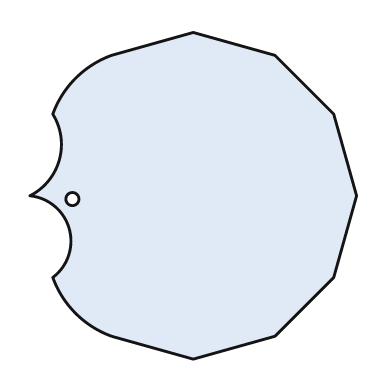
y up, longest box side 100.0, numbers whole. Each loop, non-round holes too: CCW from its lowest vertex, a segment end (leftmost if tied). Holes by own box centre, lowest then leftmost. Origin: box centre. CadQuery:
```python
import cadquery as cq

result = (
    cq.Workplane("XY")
    .moveTo(0.0, -50.0)
    .lineTo(25.0, -43.0)
    .lineTo(43.0, -25.0)
    .lineTo(50.0, 0.0)
    .lineTo(43.0, 25.0)
    .lineTo(25.0, 43.0)
    .lineTo(0.0, 50.0)
    .lineTo(-25.0, 43.0)
    .threePointArc((-36.0, 36.0), (-43.0, 25.0))
    .threePointArc((-41.0, 11.0), (-50.0, 0.0))
    .threePointArc((-38.0, -10.0), (-43.0, -25.0))
    .threePointArc((-36.0, -36.0), (-25.0, -43.0))
    .close()
    .moveTo(-37.0, -1.0)
    .circle(2.0)
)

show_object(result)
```